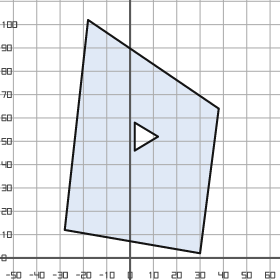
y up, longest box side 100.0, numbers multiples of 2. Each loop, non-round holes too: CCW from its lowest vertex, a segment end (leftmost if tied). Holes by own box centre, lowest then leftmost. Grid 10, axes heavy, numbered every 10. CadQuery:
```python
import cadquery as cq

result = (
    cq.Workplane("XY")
    .moveTo(30.0, 2.0)
    .lineTo(38.0, 64.0)
    .lineTo(-18.0, 102.0)
    .lineTo(-28.0, 12.0)
    .close()
    .moveTo(2.0, 46.0)
    .lineTo(12.0, 52.0)
    .lineTo(2.0, 58.0)
    .close()
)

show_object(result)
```